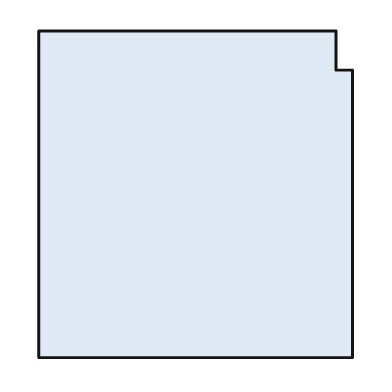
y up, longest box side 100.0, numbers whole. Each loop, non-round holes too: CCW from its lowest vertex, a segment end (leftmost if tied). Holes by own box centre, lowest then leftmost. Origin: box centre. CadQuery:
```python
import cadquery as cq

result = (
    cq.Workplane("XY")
    .moveTo(-48.0, -50.0)
    .lineTo(48.0, -50.0)
    .lineTo(48.0, 38.0)
    .lineTo(43.0, 38.0)
    .lineTo(43.0, 50.0)
    .lineTo(-48.0, 50.0)
    .close()
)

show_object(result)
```